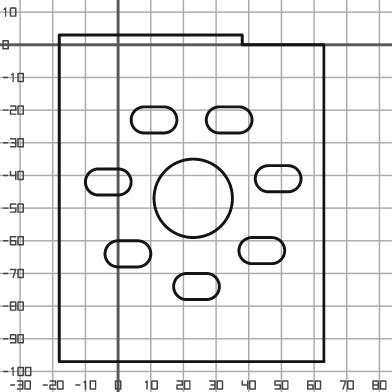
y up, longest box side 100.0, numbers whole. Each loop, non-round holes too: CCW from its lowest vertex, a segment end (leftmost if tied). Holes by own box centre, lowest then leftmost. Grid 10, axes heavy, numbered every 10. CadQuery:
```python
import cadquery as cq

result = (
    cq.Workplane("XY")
    .moveTo(-18.0, -97.0)
    .lineTo(63.0, -97.0)
    .lineTo(63.0, 0.0)
    .lineTo(38.0, 0.0)
    .lineTo(38.0, 3.0)
    .lineTo(-18.0, 3.0)
    .close()
    .moveTo(21.0, -78.0)
    .lineTo(27.0, -78.0)
    .threePointArc((31.0, -74.0), (27.0, -70.0))
    .lineTo(21.0, -70.0)
    .threePointArc((17.0, -74.0), (21.0, -78.0))
    .close()
    .moveTo(0.0, -68.0)
    .lineTo(6.0, -68.0)
    .threePointArc((10.0, -64.0), (6.0, -60.0))
    .lineTo(0.0, -60.0)
    .threePointArc((-4.0, -64.0), (0.0, -68.0))
    .close()
    .moveTo(41.0, -67.0)
    .lineTo(47.0, -67.0)
    .threePointArc((51.0, -63.0), (47.0, -59.0))
    .lineTo(41.0, -59.0)
    .threePointArc((37.0, -63.0), (41.0, -67.0))
    .close()
    .moveTo(23.0, -47.0)
    .circle(12.0)
    .moveTo(-6.0, -46.0)
    .lineTo(0.0, -46.0)
    .threePointArc((4.0, -42.0), (0.0, -38.0))
    .lineTo(-6.0, -38.0)
    .threePointArc((-10.0, -42.0), (-6.0, -46.0))
    .close()
    .moveTo(46.0, -45.0)
    .lineTo(52.0, -45.0)
    .threePointArc((56.0, -41.0), (52.0, -37.0))
    .lineTo(46.0, -37.0)
    .threePointArc((42.0, -41.0), (46.0, -45.0))
    .close()
    .moveTo(8.0, -27.0)
    .lineTo(14.0, -27.0)
    .threePointArc((18.0, -23.0), (14.0, -19.0))
    .lineTo(8.0, -19.0)
    .threePointArc((4.0, -23.0), (8.0, -27.0))
    .close()
    .moveTo(31.0, -27.0)
    .lineTo(37.0, -27.0)
    .threePointArc((41.0, -23.0), (37.0, -19.0))
    .lineTo(31.0, -19.0)
    .threePointArc((27.0, -23.0), (31.0, -27.0))
    .close()
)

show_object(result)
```